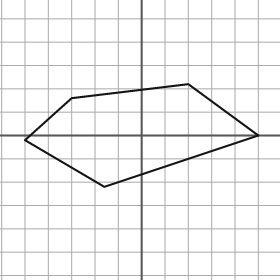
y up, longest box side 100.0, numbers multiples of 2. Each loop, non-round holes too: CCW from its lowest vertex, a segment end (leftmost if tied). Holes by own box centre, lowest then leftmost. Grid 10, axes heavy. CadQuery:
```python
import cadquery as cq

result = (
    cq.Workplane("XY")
    .moveTo(-16.0, -22.0)
    .lineTo(50.0, 0.0)
    .lineTo(20.0, 22.0)
    .lineTo(-30.0, 16.0)
    .lineTo(-50.0, -2.0)
    .close()
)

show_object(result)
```